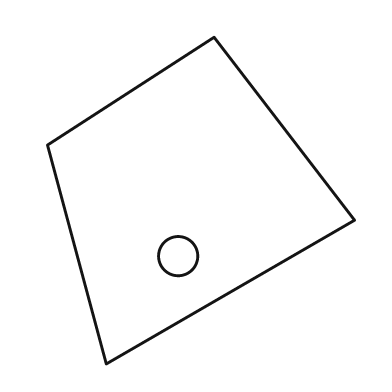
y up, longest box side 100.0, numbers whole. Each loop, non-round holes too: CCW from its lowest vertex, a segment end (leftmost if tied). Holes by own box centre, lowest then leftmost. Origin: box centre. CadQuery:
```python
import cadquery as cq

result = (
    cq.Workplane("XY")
    .moveTo(-29.0, -50.0)
    .lineTo(47.0, -6.0)
    .lineTo(4.0, 50.0)
    .lineTo(-47.0, 17.0)
    .close()
    .moveTo(-7.0, -17.0)
    .circle(6.0)
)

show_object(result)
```